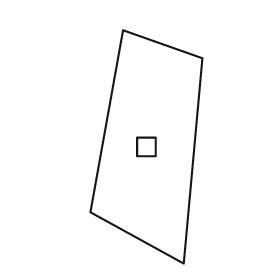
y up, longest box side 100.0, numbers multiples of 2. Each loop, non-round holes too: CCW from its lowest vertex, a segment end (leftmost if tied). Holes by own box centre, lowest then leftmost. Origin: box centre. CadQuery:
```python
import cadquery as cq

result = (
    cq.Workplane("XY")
    .moveTo(16.0, -50.0)
    .lineTo(24.0, 38.0)
    .lineTo(-10.0, 50.0)
    .lineTo(-24.0, -28.0)
    .close()
    .moveTo(-4.0, -4.0)
    .lineTo(4.0, -4.0)
    .lineTo(4.0, 4.0)
    .lineTo(-4.0, 4.0)
    .close()
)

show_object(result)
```